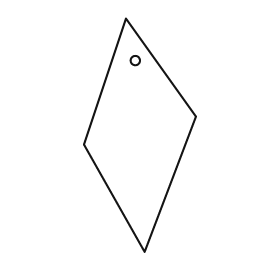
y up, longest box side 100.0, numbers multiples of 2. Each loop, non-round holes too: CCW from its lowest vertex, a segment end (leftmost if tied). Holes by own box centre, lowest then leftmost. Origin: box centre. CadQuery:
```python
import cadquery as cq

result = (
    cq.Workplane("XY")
    .moveTo(2.0, -50.0)
    .lineTo(24.0, 8.0)
    .lineTo(-6.0, 50.0)
    .lineTo(-24.0, -4.0)
    .close()
    .moveTo(-2.0, 32.0)
    .circle(2.0)
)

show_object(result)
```